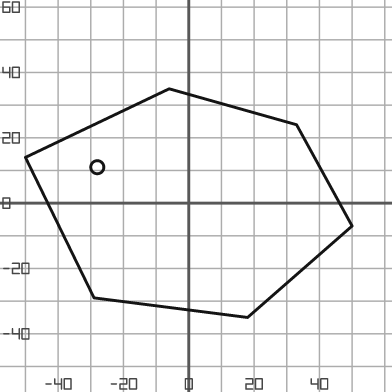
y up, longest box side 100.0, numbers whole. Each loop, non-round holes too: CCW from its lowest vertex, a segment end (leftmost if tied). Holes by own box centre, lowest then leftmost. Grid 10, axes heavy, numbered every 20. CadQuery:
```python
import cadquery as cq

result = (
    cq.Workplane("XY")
    .moveTo(18.0, -35.0)
    .lineTo(50.0, -7.0)
    .lineTo(33.0, 24.0)
    .lineTo(-6.0, 35.0)
    .lineTo(-50.0, 14.0)
    .lineTo(-29.0, -29.0)
    .close()
    .moveTo(-28.0, 11.0)
    .circle(2.0)
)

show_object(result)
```